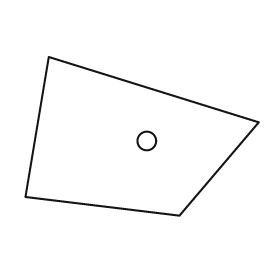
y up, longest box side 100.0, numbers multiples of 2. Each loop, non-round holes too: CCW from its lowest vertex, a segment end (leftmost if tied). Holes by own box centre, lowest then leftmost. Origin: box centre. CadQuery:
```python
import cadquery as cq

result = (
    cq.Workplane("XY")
    .moveTo(16.0, -34.0)
    .lineTo(50.0, 6.0)
    .lineTo(-40.0, 34.0)
    .lineTo(-50.0, -26.0)
    .close()
    .moveTo(2.0, -2.0)
    .circle(4.0)
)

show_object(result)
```